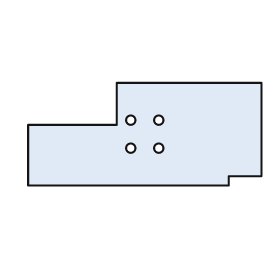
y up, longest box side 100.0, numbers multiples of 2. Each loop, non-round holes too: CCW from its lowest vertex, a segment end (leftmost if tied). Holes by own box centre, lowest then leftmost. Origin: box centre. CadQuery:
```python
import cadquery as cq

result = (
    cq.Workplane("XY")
    .moveTo(-50.0, -22.0)
    .lineTo(36.0, -22.0)
    .lineTo(36.0, -18.0)
    .lineTo(50.0, -18.0)
    .lineTo(50.0, 22.0)
    .lineTo(-12.0, 22.0)
    .lineTo(-12.0, 4.0)
    .lineTo(-50.0, 4.0)
    .close()
    .moveTo(-6.0, -6.0)
    .circle(2.0)
    .moveTo(6.0, -6.0)
    .circle(2.0)
    .moveTo(-6.0, 6.0)
    .circle(2.0)
    .moveTo(6.0, 6.0)
    .circle(2.0)
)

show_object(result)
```